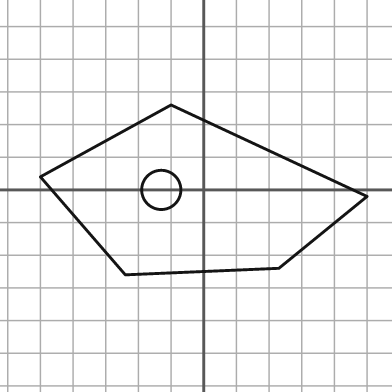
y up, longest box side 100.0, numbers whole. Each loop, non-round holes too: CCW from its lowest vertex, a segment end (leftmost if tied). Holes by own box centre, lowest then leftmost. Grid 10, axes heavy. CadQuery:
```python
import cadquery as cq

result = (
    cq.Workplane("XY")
    .moveTo(-24.0, -26.0)
    .lineTo(23.0, -24.0)
    .lineTo(50.0, -2.0)
    .lineTo(-10.0, 26.0)
    .lineTo(-50.0, 4.0)
    .close()
    .moveTo(-13.0, 0.0)
    .circle(6.0)
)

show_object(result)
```